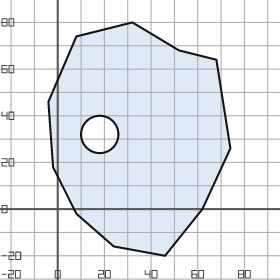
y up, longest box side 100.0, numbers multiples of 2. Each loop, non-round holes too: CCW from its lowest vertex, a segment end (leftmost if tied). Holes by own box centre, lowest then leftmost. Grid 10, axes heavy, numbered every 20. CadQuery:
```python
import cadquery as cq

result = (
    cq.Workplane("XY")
    .moveTo(46.0, -20.0)
    .lineTo(62.0, 0.0)
    .lineTo(74.0, 26.0)
    .lineTo(68.0, 64.0)
    .lineTo(52.0, 68.0)
    .lineTo(32.0, 80.0)
    .lineTo(8.0, 74.0)
    .lineTo(-4.0, 46.0)
    .lineTo(-2.0, 18.0)
    .lineTo(8.0, -2.0)
    .lineTo(24.0, -16.0)
    .close()
    .moveTo(18.0, 32.0)
    .circle(8.0)
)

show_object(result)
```